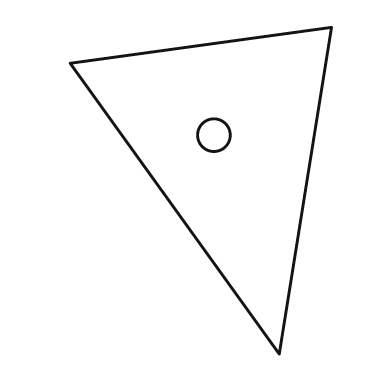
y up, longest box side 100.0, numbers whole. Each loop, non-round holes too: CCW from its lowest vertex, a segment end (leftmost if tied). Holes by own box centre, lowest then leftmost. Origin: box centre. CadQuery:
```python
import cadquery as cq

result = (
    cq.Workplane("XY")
    .moveTo(24.0, -50.0)
    .lineTo(40.0, 50.0)
    .lineTo(-40.0, 39.0)
    .close()
    .moveTo(4.0, 17.0)
    .circle(5.0)
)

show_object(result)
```